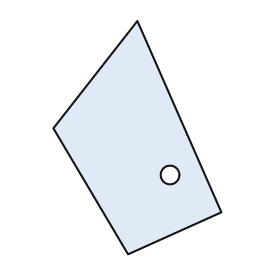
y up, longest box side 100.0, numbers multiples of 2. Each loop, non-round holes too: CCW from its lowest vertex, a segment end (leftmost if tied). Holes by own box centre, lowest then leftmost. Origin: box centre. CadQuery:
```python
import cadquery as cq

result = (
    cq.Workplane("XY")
    .moveTo(-4.0, -50.0)
    .lineTo(36.0, -32.0)
    .lineTo(0.0, 50.0)
    .lineTo(-36.0, 4.0)
    .close()
    .moveTo(14.0, -16.0)
    .circle(4.0)
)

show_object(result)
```